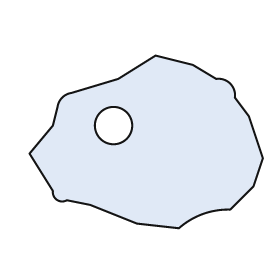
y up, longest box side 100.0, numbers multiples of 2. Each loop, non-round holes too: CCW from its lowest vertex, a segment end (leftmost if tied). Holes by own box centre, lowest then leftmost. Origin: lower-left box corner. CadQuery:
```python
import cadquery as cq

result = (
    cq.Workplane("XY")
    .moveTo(64.0, 0.0)
    .threePointArc((74.0, 6.0), (86.0, 8.0))
    .lineTo(96.0, 18.0)
    .lineTo(100.0, 30.0)
    .lineTo(94.0, 48.0)
    .lineTo(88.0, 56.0)
    .threePointArc((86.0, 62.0), (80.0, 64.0))
    .lineTo(70.0, 70.0)
    .lineTo(54.0, 74.0)
    .lineTo(38.0, 64.0)
    .lineTo(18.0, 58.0)
    .threePointArc((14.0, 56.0), (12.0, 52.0))
    .lineTo(10.0, 44.0)
    .lineTo(0.0, 32.0)
    .lineTo(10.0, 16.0)
    .threePointArc((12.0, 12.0), (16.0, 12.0))
    .lineTo(26.0, 10.0)
    .lineTo(46.0, 2.0)
    .close()
    .moveTo(36.0, 44.0)
    .circle(8.0)
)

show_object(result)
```